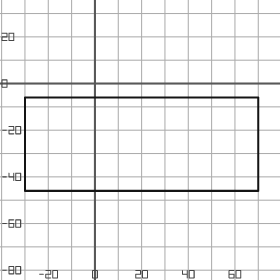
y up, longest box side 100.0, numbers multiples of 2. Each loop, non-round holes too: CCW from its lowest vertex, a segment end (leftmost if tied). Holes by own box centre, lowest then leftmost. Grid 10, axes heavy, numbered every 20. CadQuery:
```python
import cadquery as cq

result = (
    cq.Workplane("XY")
    .moveTo(-30.0, -46.0)
    .lineTo(70.0, -46.0)
    .lineTo(70.0, -6.0)
    .lineTo(-30.0, -6.0)
    .close()
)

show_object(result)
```